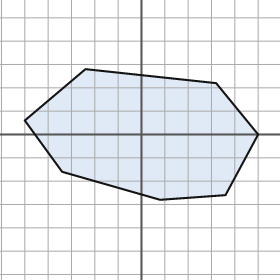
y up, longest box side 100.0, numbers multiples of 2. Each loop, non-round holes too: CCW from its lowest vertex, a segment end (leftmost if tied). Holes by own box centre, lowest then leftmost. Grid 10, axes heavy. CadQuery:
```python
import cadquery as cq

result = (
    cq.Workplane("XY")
    .moveTo(8.0, -28.0)
    .lineTo(36.0, -26.0)
    .lineTo(50.0, 0.0)
    .lineTo(32.0, 22.0)
    .lineTo(-24.0, 28.0)
    .lineTo(-50.0, 6.0)
    .lineTo(-34.0, -16.0)
    .close()
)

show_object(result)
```